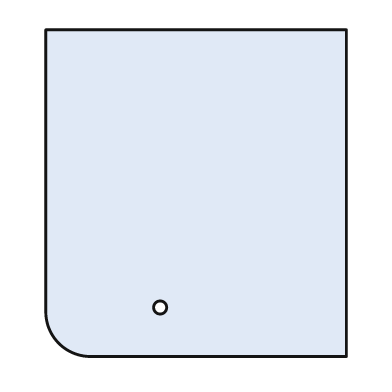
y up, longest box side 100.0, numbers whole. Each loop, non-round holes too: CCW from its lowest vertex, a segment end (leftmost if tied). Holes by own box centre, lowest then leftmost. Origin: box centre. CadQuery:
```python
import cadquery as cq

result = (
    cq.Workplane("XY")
    .moveTo(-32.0, -50.0)
    .lineTo(46.0, -50.0)
    .lineTo(46.0, 50.0)
    .lineTo(-46.0, 50.0)
    .lineTo(-46.0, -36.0)
    .threePointArc((-42.0, -46.0), (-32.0, -50.0))
    .close()
    .moveTo(-11.0, -35.0)
    .circle(2.0)
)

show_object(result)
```